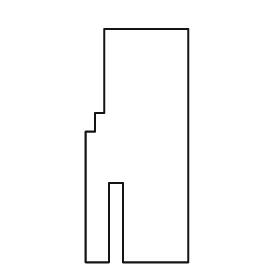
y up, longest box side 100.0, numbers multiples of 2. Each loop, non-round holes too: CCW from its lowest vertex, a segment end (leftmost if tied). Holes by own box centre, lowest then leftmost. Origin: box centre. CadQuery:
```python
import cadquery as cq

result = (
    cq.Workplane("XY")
    .moveTo(-22.0, -50.0)
    .lineTo(-12.0, -50.0)
    .lineTo(-12.0, -16.0)
    .lineTo(-6.0, -16.0)
    .lineTo(-6.0, -50.0)
    .lineTo(22.0, -50.0)
    .lineTo(22.0, 50.0)
    .lineTo(-14.0, 50.0)
    .lineTo(-14.0, 14.0)
    .lineTo(-18.0, 14.0)
    .lineTo(-18.0, 6.0)
    .lineTo(-22.0, 6.0)
    .close()
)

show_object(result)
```